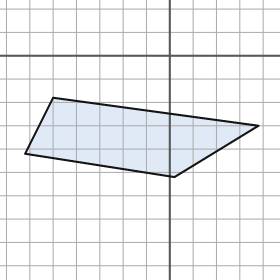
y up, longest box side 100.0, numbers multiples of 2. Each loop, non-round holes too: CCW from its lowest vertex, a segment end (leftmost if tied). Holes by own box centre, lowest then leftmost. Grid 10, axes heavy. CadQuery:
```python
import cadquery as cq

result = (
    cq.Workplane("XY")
    .moveTo(2.0, -52.0)
    .lineTo(38.0, -30.0)
    .lineTo(-50.0, -18.0)
    .lineTo(-62.0, -42.0)
    .close()
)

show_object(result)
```